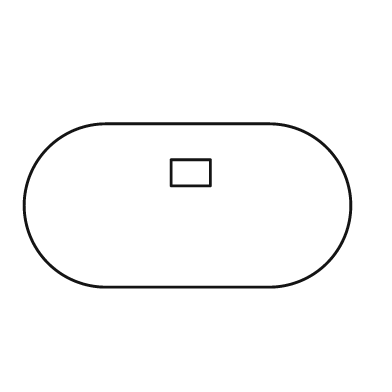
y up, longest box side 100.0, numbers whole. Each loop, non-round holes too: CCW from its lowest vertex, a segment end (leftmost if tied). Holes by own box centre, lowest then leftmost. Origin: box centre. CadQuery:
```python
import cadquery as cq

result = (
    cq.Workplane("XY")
    .moveTo(-25.0, -25.0)
    .lineTo(25.0, -25.0)
    .threePointArc((50.0, 0.0), (25.0, 25.0))
    .lineTo(-25.0, 25.0)
    .threePointArc((-50.0, 0.0), (-25.0, -25.0))
    .close()
    .moveTo(-5.0, 6.0)
    .lineTo(7.0, 6.0)
    .lineTo(7.0, 14.0)
    .lineTo(-5.0, 14.0)
    .close()
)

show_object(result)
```